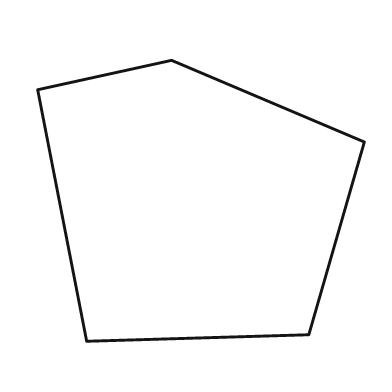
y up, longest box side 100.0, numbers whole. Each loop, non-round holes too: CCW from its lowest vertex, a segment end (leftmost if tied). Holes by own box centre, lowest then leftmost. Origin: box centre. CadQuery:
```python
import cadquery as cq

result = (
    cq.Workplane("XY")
    .moveTo(-35.0, -43.0)
    .lineTo(33.0, -41.0)
    .lineTo(50.0, 18.0)
    .lineTo(-9.0, 43.0)
    .lineTo(-50.0, 34.0)
    .close()
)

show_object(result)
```